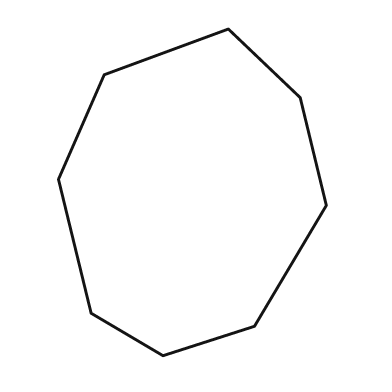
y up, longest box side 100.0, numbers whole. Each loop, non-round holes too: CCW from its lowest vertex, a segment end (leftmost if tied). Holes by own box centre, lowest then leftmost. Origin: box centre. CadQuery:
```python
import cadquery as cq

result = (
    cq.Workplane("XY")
    .moveTo(-9.0, -50.0)
    .lineTo(19.0, -41.0)
    .lineTo(41.0, -4.0)
    .lineTo(33.0, 29.0)
    .lineTo(11.0, 50.0)
    .lineTo(-27.0, 36.0)
    .lineTo(-41.0, 4.0)
    .lineTo(-31.0, -37.0)
    .close()
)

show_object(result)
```